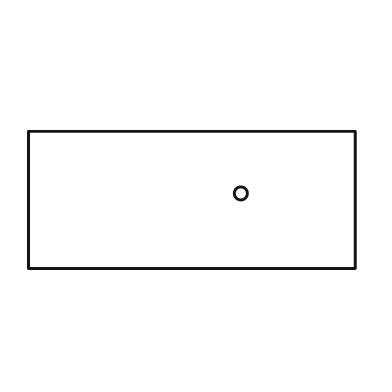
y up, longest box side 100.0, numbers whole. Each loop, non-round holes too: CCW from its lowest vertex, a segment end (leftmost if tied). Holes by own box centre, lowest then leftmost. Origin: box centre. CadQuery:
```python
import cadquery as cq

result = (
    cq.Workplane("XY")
    .moveTo(-50.0, -21.0)
    .lineTo(50.0, -21.0)
    .lineTo(50.0, 21.0)
    .lineTo(-50.0, 21.0)
    .close()
    .moveTo(15.0, 2.0)
    .circle(2.0)
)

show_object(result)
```